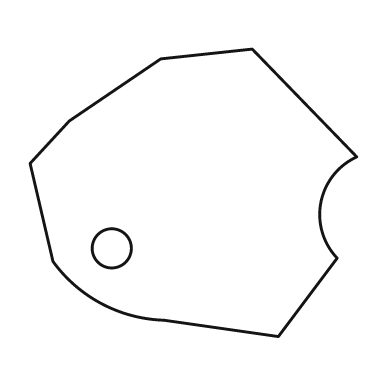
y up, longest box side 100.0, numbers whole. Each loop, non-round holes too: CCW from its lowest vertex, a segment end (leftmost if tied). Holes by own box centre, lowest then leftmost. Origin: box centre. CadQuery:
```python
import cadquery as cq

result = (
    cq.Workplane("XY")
    .moveTo(26.0, -44.0)
    .lineTo(44.0, -20.0)
    .threePointArc((39.0, -3.0), (50.0, 11.0))
    .lineTo(18.0, 44.0)
    .lineTo(-10.0, 41.0)
    .lineTo(-38.0, 22.0)
    .lineTo(-50.0, 9.0)
    .lineTo(-43.0, -21.0)
    .threePointArc((-28.0, -34.0), (-9.0, -39.0))
    .close()
    .moveTo(-25.0, -17.0)
    .circle(6.0)
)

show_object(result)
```